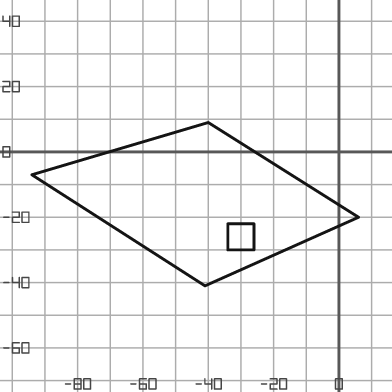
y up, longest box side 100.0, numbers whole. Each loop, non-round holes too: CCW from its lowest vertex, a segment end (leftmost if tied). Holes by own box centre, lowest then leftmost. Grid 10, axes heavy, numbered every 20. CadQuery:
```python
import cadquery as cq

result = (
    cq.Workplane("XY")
    .moveTo(-41.0, -41.0)
    .lineTo(6.0, -20.0)
    .lineTo(-40.0, 9.0)
    .lineTo(-94.0, -7.0)
    .close()
    .moveTo(-34.0, -30.0)
    .lineTo(-26.0, -30.0)
    .lineTo(-26.0, -22.0)
    .lineTo(-34.0, -22.0)
    .close()
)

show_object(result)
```